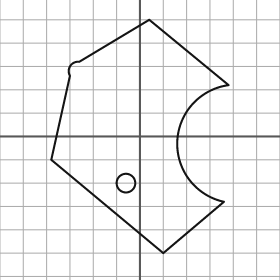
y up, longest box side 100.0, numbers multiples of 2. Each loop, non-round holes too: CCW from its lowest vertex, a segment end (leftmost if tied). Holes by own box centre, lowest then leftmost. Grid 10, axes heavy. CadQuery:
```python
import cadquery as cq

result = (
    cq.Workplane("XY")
    .moveTo(10.0, -50.0)
    .lineTo(36.0, -28.0)
    .threePointArc((16.0, -2.0), (38.0, 22.0))
    .lineTo(4.0, 50.0)
    .lineTo(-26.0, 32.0)
    .threePointArc((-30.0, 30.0), (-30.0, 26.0))
    .lineTo(-38.0, -10.0)
    .close()
    .moveTo(-6.0, -20.0)
    .circle(4.0)
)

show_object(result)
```